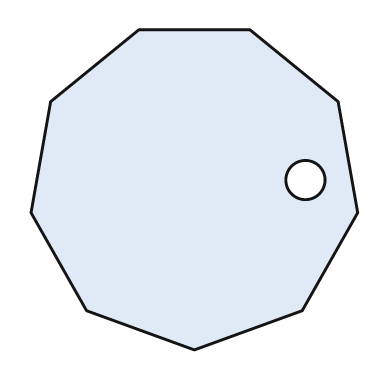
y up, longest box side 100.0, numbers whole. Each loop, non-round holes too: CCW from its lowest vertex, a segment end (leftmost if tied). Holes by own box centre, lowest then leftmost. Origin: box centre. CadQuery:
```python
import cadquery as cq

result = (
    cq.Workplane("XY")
    .moveTo(0.0, -49.0)
    .lineTo(33.0, -37.0)
    .lineTo(50.0, -7.0)
    .lineTo(44.0, 27.0)
    .lineTo(17.0, 49.0)
    .lineTo(-17.0, 49.0)
    .lineTo(-44.0, 27.0)
    .lineTo(-50.0, -7.0)
    .lineTo(-33.0, -37.0)
    .close()
    .moveTo(34.0, 3.0)
    .circle(6.0)
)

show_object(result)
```